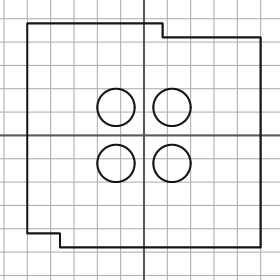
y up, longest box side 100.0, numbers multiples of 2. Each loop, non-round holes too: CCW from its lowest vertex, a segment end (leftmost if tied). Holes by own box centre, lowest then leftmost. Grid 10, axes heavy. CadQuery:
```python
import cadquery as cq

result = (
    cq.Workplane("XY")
    .moveTo(-36.0, -48.0)
    .lineTo(50.0, -48.0)
    .lineTo(50.0, 42.0)
    .lineTo(8.0, 42.0)
    .lineTo(8.0, 48.0)
    .lineTo(-50.0, 48.0)
    .lineTo(-50.0, -42.0)
    .lineTo(-36.0, -42.0)
    .close()
    .moveTo(-12.0, -12.0)
    .circle(8.0)
    .moveTo(12.0, -12.0)
    .circle(8.0)
    .moveTo(-12.0, 12.0)
    .circle(8.0)
    .moveTo(12.0, 12.0)
    .circle(8.0)
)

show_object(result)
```